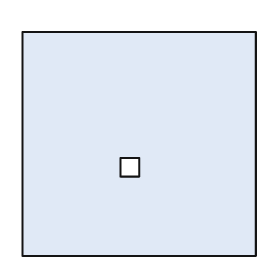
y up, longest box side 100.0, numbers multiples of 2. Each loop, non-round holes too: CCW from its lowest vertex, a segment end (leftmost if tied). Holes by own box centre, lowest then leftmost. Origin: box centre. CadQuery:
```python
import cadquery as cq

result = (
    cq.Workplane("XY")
    .moveTo(-50.0, -48.0)
    .lineTo(50.0, -48.0)
    .lineTo(50.0, 48.0)
    .lineTo(-50.0, 48.0)
    .close()
    .moveTo(-8.0, -14.0)
    .lineTo(0.0, -14.0)
    .lineTo(0.0, -6.0)
    .lineTo(-8.0, -6.0)
    .close()
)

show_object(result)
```